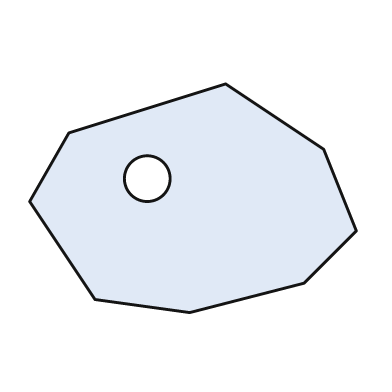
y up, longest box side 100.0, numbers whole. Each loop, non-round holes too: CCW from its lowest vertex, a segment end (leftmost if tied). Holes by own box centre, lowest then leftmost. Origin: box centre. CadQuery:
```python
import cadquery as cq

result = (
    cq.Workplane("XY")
    .moveTo(-1.0, -35.0)
    .lineTo(34.0, -26.0)
    .lineTo(50.0, -10.0)
    .lineTo(40.0, 15.0)
    .lineTo(10.0, 35.0)
    .lineTo(-38.0, 20.0)
    .lineTo(-50.0, -1.0)
    .lineTo(-30.0, -31.0)
    .close()
    .moveTo(-14.0, 6.0)
    .circle(7.0)
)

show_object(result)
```